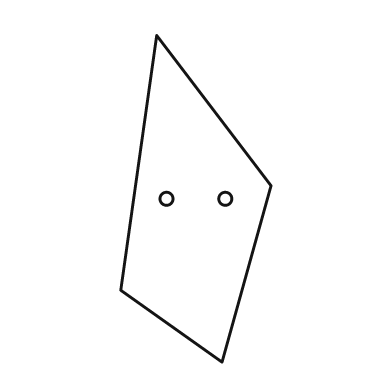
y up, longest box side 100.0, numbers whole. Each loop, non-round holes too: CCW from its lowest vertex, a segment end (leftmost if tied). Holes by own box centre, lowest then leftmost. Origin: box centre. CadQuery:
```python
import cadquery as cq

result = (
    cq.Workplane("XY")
    .moveTo(8.0, -50.0)
    .lineTo(23.0, 4.0)
    .lineTo(-12.0, 50.0)
    .lineTo(-23.0, -28.0)
    .close()
    .moveTo(-9.0, 0.0)
    .circle(2.0)
    .moveTo(9.0, 0.0)
    .circle(2.0)
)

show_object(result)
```